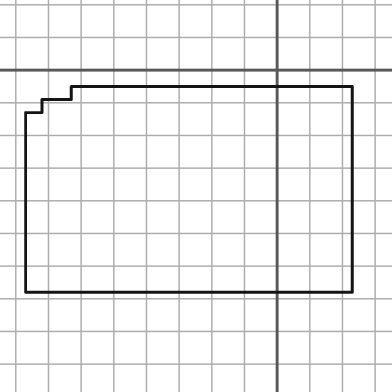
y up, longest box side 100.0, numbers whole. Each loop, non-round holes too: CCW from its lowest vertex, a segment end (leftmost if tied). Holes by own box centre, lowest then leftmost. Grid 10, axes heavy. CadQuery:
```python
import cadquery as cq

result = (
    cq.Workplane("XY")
    .moveTo(-77.0, -68.0)
    .lineTo(23.0, -68.0)
    .lineTo(23.0, -5.0)
    .lineTo(-63.0, -5.0)
    .lineTo(-63.0, -9.0)
    .lineTo(-72.0, -9.0)
    .lineTo(-72.0, -13.0)
    .lineTo(-77.0, -13.0)
    .close()
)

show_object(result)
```